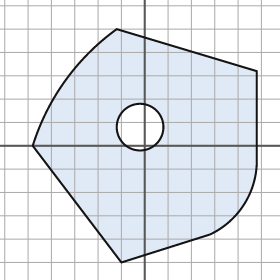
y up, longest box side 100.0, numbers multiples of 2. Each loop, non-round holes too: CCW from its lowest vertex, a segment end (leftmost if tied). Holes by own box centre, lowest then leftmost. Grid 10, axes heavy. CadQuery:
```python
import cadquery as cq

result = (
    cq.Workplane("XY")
    .moveTo(-10.0, -50.0)
    .lineTo(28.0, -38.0)
    .threePointArc((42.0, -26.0), (48.0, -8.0))
    .lineTo(48.0, 32.0)
    .lineTo(-12.0, 50.0)
    .threePointArc((-34.0, 28.0), (-48.0, 0.0))
    .close()
    .moveTo(-2.0, 8.0)
    .circle(10.0)
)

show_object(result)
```